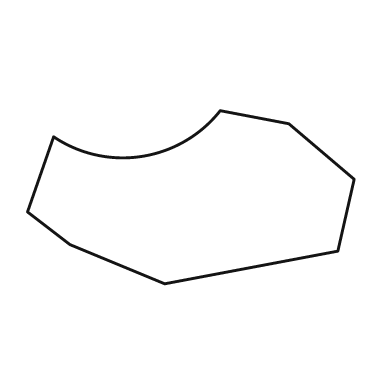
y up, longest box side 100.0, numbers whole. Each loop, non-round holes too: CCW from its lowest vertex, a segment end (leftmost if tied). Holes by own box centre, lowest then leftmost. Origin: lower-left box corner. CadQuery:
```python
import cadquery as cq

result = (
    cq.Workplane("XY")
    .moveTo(42.0, 0.0)
    .lineTo(95.0, 10.0)
    .lineTo(100.0, 32.0)
    .lineTo(80.0, 49.0)
    .lineTo(59.0, 53.0)
    .threePointArc((35.0, 39.0), (8.0, 45.0))
    .lineTo(0.0, 22.0)
    .lineTo(13.0, 12.0)
    .close()
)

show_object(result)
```